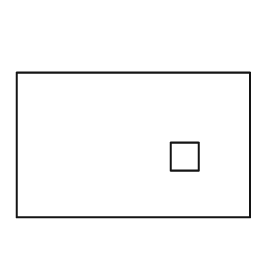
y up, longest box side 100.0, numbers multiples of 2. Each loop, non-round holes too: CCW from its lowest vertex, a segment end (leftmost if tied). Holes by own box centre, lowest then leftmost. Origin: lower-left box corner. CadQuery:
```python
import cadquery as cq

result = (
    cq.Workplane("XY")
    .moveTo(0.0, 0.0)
    .lineTo(100.0, 0.0)
    .lineTo(100.0, 62.0)
    .lineTo(0.0, 62.0)
    .close()
    .moveTo(66.0, 20.0)
    .lineTo(78.0, 20.0)
    .lineTo(78.0, 32.0)
    .lineTo(66.0, 32.0)
    .close()
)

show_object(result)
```